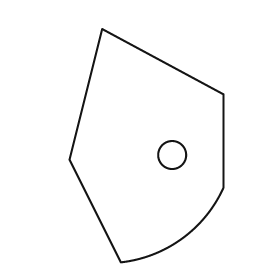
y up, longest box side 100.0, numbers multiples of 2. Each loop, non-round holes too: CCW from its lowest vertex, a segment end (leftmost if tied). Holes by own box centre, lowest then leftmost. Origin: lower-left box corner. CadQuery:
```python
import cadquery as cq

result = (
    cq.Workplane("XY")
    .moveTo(22.0, 0.0)
    .threePointArc((48.0, 10.0), (66.0, 32.0))
    .lineTo(66.0, 72.0)
    .lineTo(14.0, 100.0)
    .lineTo(0.0, 44.0)
    .close()
    .moveTo(44.0, 46.0)
    .circle(6.0)
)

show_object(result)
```